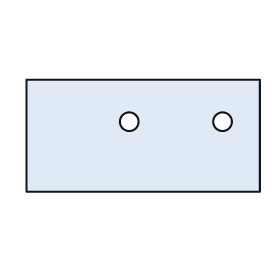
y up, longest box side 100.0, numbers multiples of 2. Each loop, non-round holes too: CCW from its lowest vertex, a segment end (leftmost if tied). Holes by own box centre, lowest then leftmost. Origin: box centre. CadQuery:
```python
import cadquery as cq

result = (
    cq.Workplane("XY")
    .moveTo(-50.0, -24.0)
    .lineTo(50.0, -24.0)
    .lineTo(50.0, 24.0)
    .lineTo(-50.0, 24.0)
    .close()
    .moveTo(-6.0, 6.0)
    .circle(4.0)
    .moveTo(34.0, 6.0)
    .circle(4.0)
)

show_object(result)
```